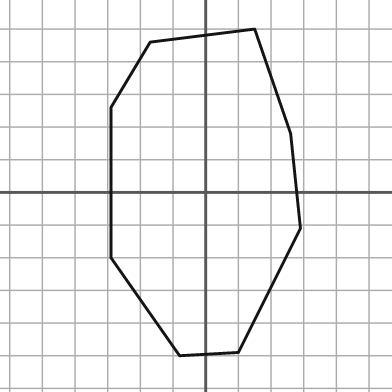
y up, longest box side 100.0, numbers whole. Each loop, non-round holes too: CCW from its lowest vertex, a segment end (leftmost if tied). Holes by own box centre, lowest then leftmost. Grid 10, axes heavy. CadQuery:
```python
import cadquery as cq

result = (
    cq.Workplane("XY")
    .moveTo(-8.0, -50.0)
    .lineTo(10.0, -49.0)
    .lineTo(29.0, -11.0)
    .lineTo(26.0, 18.0)
    .lineTo(15.0, 50.0)
    .lineTo(-17.0, 46.0)
    .lineTo(-29.0, 26.0)
    .lineTo(-29.0, -20.0)
    .close()
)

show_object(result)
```